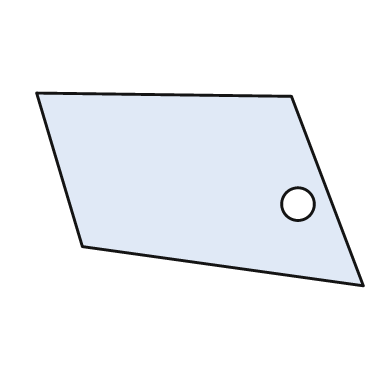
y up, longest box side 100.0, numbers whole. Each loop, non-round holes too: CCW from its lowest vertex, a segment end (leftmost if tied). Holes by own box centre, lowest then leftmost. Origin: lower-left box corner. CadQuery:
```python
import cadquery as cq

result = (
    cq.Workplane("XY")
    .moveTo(100.0, 0.0)
    .lineTo(78.0, 58.0)
    .lineTo(0.0, 59.0)
    .lineTo(14.0, 12.0)
    .close()
    .moveTo(80.0, 25.0)
    .circle(5.0)
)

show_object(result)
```